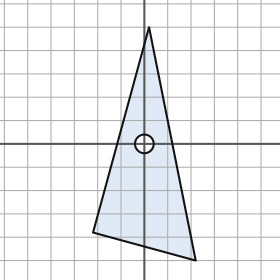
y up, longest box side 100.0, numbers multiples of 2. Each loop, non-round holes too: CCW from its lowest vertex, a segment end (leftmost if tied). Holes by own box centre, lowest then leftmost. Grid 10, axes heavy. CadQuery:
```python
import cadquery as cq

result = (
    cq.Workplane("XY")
    .moveTo(22.0, -50.0)
    .lineTo(2.0, 50.0)
    .lineTo(-22.0, -38.0)
    .close()
    .moveTo(0.0, 0.0)
    .circle(4.0)
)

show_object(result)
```